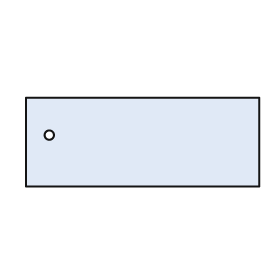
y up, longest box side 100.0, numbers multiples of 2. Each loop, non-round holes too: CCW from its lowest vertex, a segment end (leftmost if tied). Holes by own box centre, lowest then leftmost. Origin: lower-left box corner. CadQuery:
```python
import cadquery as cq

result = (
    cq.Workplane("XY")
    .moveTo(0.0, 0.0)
    .lineTo(100.0, 0.0)
    .lineTo(100.0, 38.0)
    .lineTo(0.0, 38.0)
    .close()
    .moveTo(10.0, 22.0)
    .circle(2.0)
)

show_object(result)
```